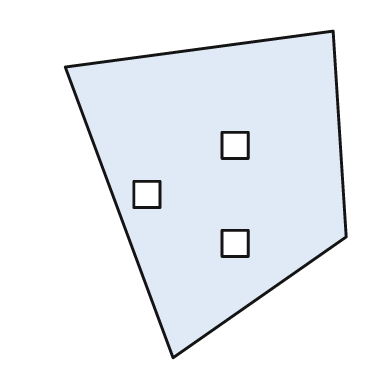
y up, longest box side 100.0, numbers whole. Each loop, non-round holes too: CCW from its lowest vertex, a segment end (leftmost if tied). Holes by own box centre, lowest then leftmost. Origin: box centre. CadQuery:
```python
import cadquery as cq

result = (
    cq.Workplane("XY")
    .moveTo(-10.0, -50.0)
    .lineTo(43.0, -13.0)
    .lineTo(39.0, 50.0)
    .lineTo(-43.0, 39.0)
    .close()
    .moveTo(5.0, -19.0)
    .lineTo(13.0, -19.0)
    .lineTo(13.0, -11.0)
    .lineTo(5.0, -11.0)
    .close()
    .moveTo(-22.0, -4.0)
    .lineTo(-14.0, -4.0)
    .lineTo(-14.0, 4.0)
    .lineTo(-22.0, 4.0)
    .close()
    .moveTo(5.0, 11.0)
    .lineTo(13.0, 11.0)
    .lineTo(13.0, 19.0)
    .lineTo(5.0, 19.0)
    .close()
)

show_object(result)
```